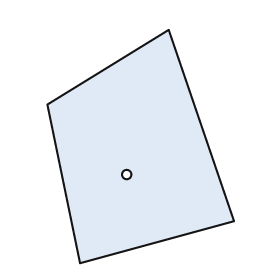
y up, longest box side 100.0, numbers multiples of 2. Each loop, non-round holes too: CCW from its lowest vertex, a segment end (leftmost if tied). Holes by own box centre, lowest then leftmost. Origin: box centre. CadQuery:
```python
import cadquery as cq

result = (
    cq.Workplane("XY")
    .moveTo(-26.0, -50.0)
    .lineTo(40.0, -32.0)
    .lineTo(12.0, 50.0)
    .lineTo(-40.0, 18.0)
    .close()
    .moveTo(-6.0, -12.0)
    .circle(2.0)
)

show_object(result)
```